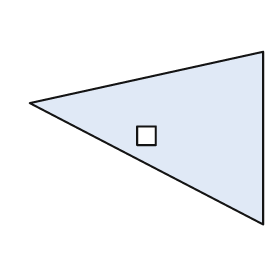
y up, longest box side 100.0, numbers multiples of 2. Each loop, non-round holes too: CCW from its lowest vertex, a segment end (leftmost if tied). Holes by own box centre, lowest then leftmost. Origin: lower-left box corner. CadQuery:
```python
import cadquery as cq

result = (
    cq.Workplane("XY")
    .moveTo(100.0, 0.0)
    .lineTo(100.0, 74.0)
    .lineTo(0.0, 52.0)
    .close()
    .moveTo(46.0, 34.0)
    .lineTo(54.0, 34.0)
    .lineTo(54.0, 42.0)
    .lineTo(46.0, 42.0)
    .close()
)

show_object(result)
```